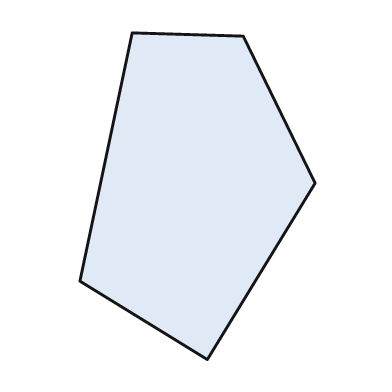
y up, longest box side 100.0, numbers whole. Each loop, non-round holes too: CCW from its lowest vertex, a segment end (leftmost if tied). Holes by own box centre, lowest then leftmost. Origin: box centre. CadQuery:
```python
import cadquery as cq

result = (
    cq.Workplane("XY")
    .moveTo(3.0, -50.0)
    .lineTo(36.0, 4.0)
    .lineTo(14.0, 49.0)
    .lineTo(-20.0, 50.0)
    .lineTo(-36.0, -26.0)
    .close()
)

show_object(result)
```